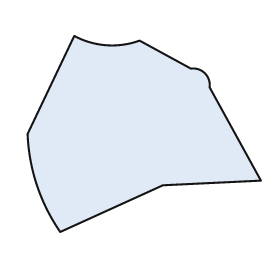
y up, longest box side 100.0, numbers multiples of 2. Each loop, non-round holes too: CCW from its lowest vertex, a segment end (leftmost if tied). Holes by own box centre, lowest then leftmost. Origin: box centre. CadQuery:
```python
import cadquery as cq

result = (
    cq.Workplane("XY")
    .moveTo(-36.0, -42.0)
    .lineTo(8.0, -22.0)
    .lineTo(50.0, -20.0)
    .lineTo(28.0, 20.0)
    .threePointArc((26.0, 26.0), (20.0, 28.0))
    .lineTo(-2.0, 40.0)
    .threePointArc((-16.0, 38.0), (-30.0, 42.0))
    .lineTo(-50.0, 0.0)
    .threePointArc((-46.0, -22.0), (-36.0, -42.0))
    .close()
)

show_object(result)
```